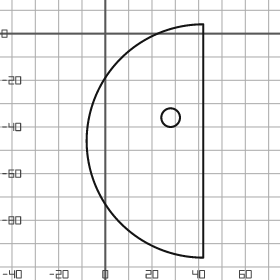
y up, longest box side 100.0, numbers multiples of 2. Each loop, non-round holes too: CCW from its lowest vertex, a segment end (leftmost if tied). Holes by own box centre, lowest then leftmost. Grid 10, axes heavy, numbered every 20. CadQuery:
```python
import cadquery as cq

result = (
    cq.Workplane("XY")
    .moveTo(42.0, -96.0)
    .lineTo(42.0, 4.0)
    .threePointArc((-8.0, -46.0), (42.0, -96.0))
    .close()
    .moveTo(28.0, -36.0)
    .circle(4.0)
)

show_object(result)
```